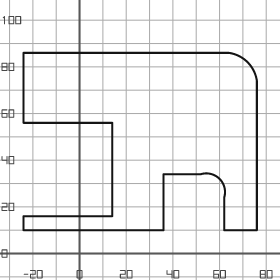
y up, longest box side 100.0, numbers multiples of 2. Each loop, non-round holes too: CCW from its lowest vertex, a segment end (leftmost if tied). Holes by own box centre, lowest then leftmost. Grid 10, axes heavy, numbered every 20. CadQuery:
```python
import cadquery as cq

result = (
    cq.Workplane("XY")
    .moveTo(-24.0, 10.0)
    .lineTo(36.0, 10.0)
    .lineTo(36.0, 34.0)
    .lineTo(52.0, 34.0)
    .threePointArc((60.0, 32.0), (62.0, 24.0))
    .lineTo(62.0, 10.0)
    .lineTo(76.0, 10.0)
    .lineTo(76.0, 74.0)
    .threePointArc((72.0, 82.0), (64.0, 86.0))
    .lineTo(-24.0, 86.0)
    .lineTo(-24.0, 56.0)
    .lineTo(14.0, 56.0)
    .lineTo(14.0, 16.0)
    .lineTo(-24.0, 16.0)
    .close()
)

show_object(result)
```